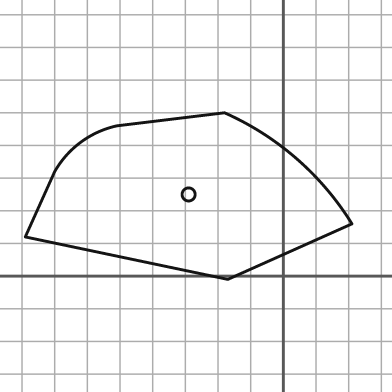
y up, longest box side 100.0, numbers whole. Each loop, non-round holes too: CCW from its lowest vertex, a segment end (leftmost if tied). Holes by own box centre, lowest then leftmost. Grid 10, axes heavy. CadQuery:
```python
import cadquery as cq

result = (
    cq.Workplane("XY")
    .moveTo(-17.0, -1.0)
    .lineTo(21.0, 16.0)
    .threePointArc((4.0, 36.0), (-18.0, 50.0))
    .lineTo(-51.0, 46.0)
    .threePointArc((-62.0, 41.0), (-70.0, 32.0))
    .lineTo(-79.0, 12.0)
    .close()
    .moveTo(-29.0, 25.0)
    .circle(2.0)
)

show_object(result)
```